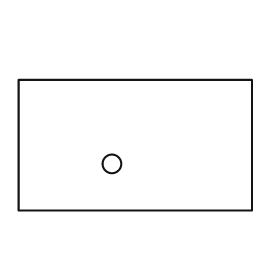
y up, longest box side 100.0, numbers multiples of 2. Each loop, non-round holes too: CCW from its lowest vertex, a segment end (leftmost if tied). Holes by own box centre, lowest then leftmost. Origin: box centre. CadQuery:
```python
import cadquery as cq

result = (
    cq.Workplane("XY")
    .moveTo(-50.0, -28.0)
    .lineTo(50.0, -28.0)
    .lineTo(50.0, 28.0)
    .lineTo(-50.0, 28.0)
    .close()
    .moveTo(-10.0, -8.0)
    .circle(4.0)
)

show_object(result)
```